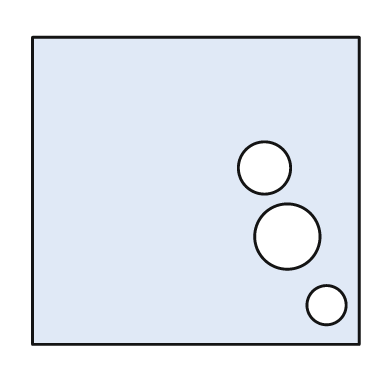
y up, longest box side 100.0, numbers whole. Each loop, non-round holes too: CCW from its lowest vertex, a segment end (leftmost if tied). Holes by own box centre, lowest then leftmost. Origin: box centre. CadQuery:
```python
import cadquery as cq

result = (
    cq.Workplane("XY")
    .moveTo(-50.0, -47.0)
    .lineTo(50.0, -47.0)
    .lineTo(50.0, 47.0)
    .lineTo(-50.0, 47.0)
    .close()
    .moveTo(40.0, -35.0)
    .circle(6.0)
    .moveTo(28.0, -14.0)
    .circle(10.0)
    .moveTo(21.0, 7.0)
    .circle(8.0)
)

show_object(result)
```